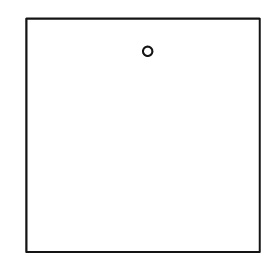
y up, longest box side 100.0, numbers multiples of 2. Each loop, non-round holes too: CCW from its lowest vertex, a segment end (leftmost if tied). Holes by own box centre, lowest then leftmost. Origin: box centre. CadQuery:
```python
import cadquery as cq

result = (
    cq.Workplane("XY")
    .moveTo(-50.0, -50.0)
    .lineTo(50.0, -50.0)
    .lineTo(50.0, 50.0)
    .lineTo(-50.0, 50.0)
    .close()
    .moveTo(2.0, 36.0)
    .circle(2.0)
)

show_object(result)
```